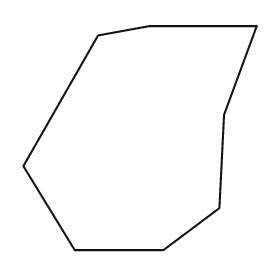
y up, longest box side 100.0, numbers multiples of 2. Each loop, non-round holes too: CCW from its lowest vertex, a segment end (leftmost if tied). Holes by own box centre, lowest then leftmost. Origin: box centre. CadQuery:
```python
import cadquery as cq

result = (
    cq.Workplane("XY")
    .moveTo(-28.0, -48.0)
    .lineTo(10.0, -48.0)
    .lineTo(34.0, -30.0)
    .lineTo(36.0, 10.0)
    .lineTo(50.0, 48.0)
    .lineTo(4.0, 48.0)
    .lineTo(-18.0, 44.0)
    .lineTo(-50.0, -12.0)
    .close()
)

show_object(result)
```